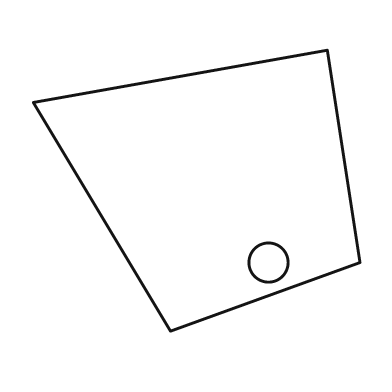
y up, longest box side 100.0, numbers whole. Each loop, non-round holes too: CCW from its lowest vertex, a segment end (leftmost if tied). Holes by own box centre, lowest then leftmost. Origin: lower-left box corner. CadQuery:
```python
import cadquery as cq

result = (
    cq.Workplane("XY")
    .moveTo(42.0, 0.0)
    .lineTo(100.0, 21.0)
    .lineTo(90.0, 86.0)
    .lineTo(0.0, 70.0)
    .close()
    .moveTo(72.0, 21.0)
    .circle(6.0)
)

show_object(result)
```